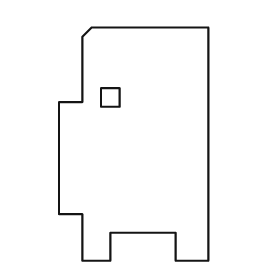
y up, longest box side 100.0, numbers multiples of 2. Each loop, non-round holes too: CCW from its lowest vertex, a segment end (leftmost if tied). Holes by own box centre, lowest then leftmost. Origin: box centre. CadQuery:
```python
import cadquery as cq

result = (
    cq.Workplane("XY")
    .moveTo(-22.0, -50.0)
    .lineTo(-10.0, -50.0)
    .lineTo(-10.0, -38.0)
    .lineTo(18.0, -38.0)
    .lineTo(18.0, -50.0)
    .lineTo(32.0, -50.0)
    .lineTo(32.0, 50.0)
    .lineTo(-18.0, 50.0)
    .lineTo(-22.0, 46.0)
    .lineTo(-22.0, 18.0)
    .lineTo(-32.0, 18.0)
    .lineTo(-32.0, -30.0)
    .lineTo(-22.0, -30.0)
    .close()
    .moveTo(-14.0, 16.0)
    .lineTo(-6.0, 16.0)
    .lineTo(-6.0, 24.0)
    .lineTo(-14.0, 24.0)
    .close()
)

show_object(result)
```